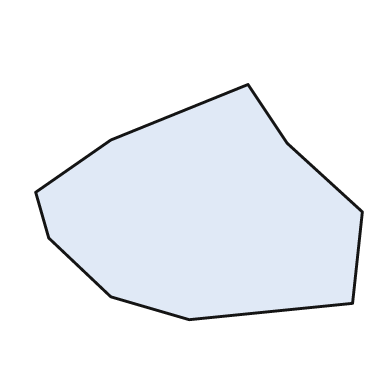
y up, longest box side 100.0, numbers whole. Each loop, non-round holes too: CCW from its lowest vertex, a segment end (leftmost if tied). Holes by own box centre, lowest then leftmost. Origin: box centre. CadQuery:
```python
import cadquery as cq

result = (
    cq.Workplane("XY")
    .moveTo(-3.0, -36.0)
    .lineTo(47.0, -31.0)
    .lineTo(50.0, -3.0)
    .lineTo(27.0, 18.0)
    .lineTo(15.0, 36.0)
    .lineTo(-27.0, 19.0)
    .lineTo(-50.0, 3.0)
    .lineTo(-46.0, -11.0)
    .lineTo(-27.0, -29.0)
    .close()
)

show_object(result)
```